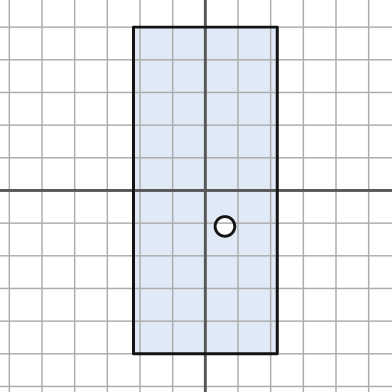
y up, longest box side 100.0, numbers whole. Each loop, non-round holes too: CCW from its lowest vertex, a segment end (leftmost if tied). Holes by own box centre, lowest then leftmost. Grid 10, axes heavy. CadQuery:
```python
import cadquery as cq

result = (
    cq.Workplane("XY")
    .moveTo(-22.0, -50.0)
    .lineTo(22.0, -50.0)
    .lineTo(22.0, 50.0)
    .lineTo(-22.0, 50.0)
    .close()
    .moveTo(6.0, -11.0)
    .circle(3.0)
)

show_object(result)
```